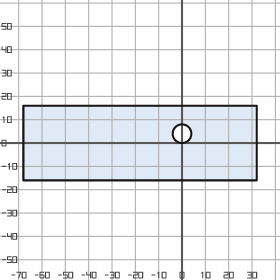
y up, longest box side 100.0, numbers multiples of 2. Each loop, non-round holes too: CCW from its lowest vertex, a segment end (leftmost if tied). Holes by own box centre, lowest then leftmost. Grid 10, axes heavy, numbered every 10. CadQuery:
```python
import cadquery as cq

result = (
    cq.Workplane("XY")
    .moveTo(-68.0, -16.0)
    .lineTo(32.0, -16.0)
    .lineTo(32.0, 16.0)
    .lineTo(-68.0, 16.0)
    .close()
    .moveTo(0.0, 4.0)
    .circle(4.0)
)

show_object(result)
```